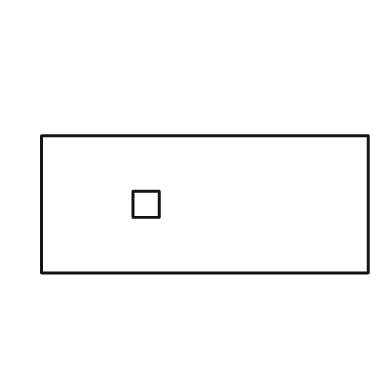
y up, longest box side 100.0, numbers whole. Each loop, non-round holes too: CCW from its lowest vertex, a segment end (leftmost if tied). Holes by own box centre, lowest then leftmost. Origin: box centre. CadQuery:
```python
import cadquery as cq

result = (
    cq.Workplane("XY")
    .moveTo(-50.0, -21.0)
    .lineTo(50.0, -21.0)
    .lineTo(50.0, 21.0)
    .lineTo(-50.0, 21.0)
    .close()
    .moveTo(-22.0, -4.0)
    .lineTo(-14.0, -4.0)
    .lineTo(-14.0, 4.0)
    .lineTo(-22.0, 4.0)
    .close()
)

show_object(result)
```